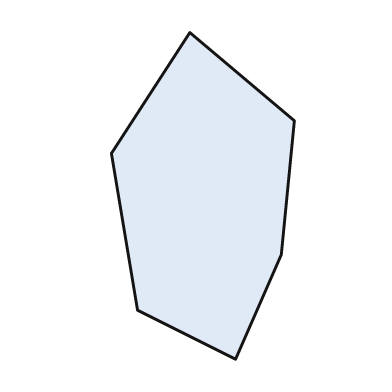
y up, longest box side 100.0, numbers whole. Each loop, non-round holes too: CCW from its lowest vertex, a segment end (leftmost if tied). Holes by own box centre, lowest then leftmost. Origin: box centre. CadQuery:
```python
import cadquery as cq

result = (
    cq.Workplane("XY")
    .moveTo(10.0, -50.0)
    .lineTo(24.0, -18.0)
    .lineTo(28.0, 23.0)
    .lineTo(-4.0, 50.0)
    .lineTo(-28.0, 13.0)
    .lineTo(-20.0, -35.0)
    .close()
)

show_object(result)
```